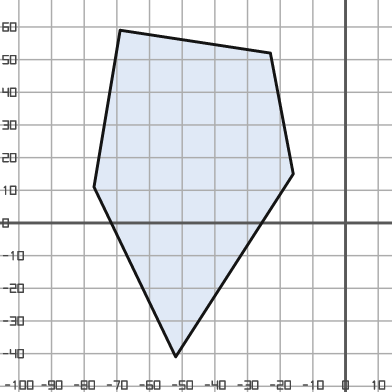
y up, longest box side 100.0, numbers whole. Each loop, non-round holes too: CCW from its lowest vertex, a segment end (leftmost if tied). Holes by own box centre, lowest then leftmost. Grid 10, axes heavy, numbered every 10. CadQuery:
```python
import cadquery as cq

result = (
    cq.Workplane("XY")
    .moveTo(-52.0, -41.0)
    .lineTo(-16.0, 15.0)
    .lineTo(-23.0, 52.0)
    .lineTo(-69.0, 59.0)
    .lineTo(-77.0, 11.0)
    .close()
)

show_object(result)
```